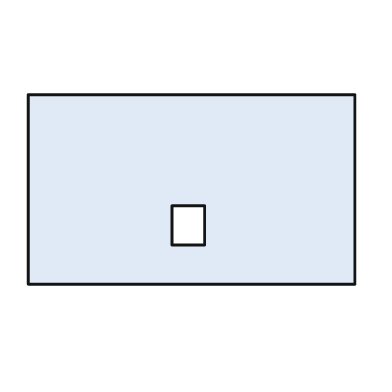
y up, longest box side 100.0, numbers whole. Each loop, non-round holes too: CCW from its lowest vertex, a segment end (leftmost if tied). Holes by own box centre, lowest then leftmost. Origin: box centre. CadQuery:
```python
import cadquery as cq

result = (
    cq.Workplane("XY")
    .moveTo(-50.0, -29.0)
    .lineTo(50.0, -29.0)
    .lineTo(50.0, 29.0)
    .lineTo(-50.0, 29.0)
    .close()
    .moveTo(-6.0, -17.0)
    .lineTo(4.0, -17.0)
    .lineTo(4.0, -5.0)
    .lineTo(-6.0, -5.0)
    .close()
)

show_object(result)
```